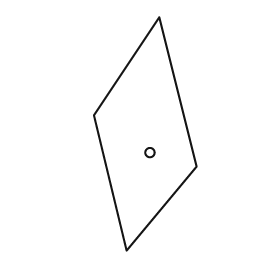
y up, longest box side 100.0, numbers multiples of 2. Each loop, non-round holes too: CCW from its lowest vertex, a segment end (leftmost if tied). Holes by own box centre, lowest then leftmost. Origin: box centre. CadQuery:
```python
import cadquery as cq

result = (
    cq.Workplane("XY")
    .moveTo(-8.0, -50.0)
    .lineTo(22.0, -14.0)
    .lineTo(6.0, 50.0)
    .lineTo(-22.0, 8.0)
    .close()
    .moveTo(2.0, -8.0)
    .circle(2.0)
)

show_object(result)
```